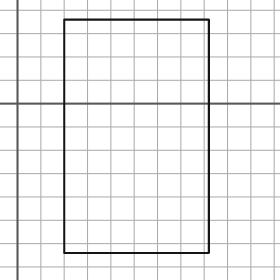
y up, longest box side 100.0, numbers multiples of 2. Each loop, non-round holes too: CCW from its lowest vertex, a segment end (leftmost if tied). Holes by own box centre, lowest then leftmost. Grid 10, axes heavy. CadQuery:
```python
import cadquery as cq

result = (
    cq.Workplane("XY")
    .moveTo(20.0, -64.0)
    .lineTo(82.0, -64.0)
    .lineTo(82.0, 36.0)
    .lineTo(20.0, 36.0)
    .close()
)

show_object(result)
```